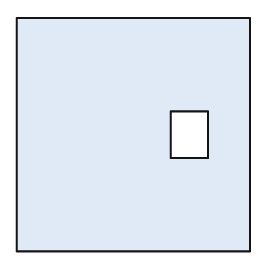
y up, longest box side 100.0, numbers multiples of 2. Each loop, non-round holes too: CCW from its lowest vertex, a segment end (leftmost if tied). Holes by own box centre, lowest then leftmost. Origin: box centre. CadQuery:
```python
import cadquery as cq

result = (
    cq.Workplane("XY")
    .moveTo(-50.0, -50.0)
    .lineTo(50.0, -50.0)
    .lineTo(50.0, 50.0)
    .lineTo(-50.0, 50.0)
    .close()
    .moveTo(16.0, -10.0)
    .lineTo(32.0, -10.0)
    .lineTo(32.0, 10.0)
    .lineTo(16.0, 10.0)
    .close()
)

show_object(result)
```